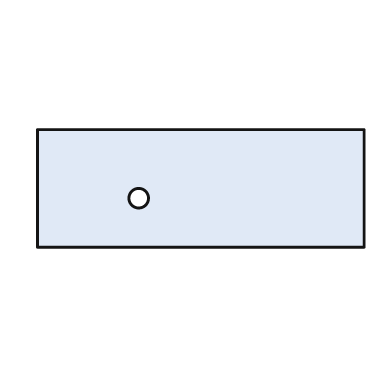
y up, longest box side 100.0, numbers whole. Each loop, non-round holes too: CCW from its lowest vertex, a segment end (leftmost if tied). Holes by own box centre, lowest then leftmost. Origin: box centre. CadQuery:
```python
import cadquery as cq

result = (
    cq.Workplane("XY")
    .moveTo(-50.0, -18.0)
    .lineTo(50.0, -18.0)
    .lineTo(50.0, 18.0)
    .lineTo(-50.0, 18.0)
    .close()
    .moveTo(-19.0, -3.0)
    .circle(3.0)
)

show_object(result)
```